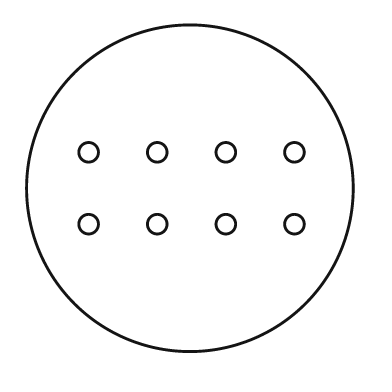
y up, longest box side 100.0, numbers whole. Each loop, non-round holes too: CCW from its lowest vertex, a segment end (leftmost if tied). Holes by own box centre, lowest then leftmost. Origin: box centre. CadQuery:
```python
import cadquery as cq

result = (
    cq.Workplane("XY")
    .moveTo(0.0, 0.0)
    .circle(50.0)
    .moveTo(-31.0, -11.0)
    .circle(3.0)
    .moveTo(-10.0, -11.0)
    .circle(3.0)
    .moveTo(11.0, -11.0)
    .circle(3.0)
    .moveTo(32.0, -11.0)
    .circle(3.0)
    .moveTo(-31.0, 11.0)
    .circle(3.0)
    .moveTo(-10.0, 11.0)
    .circle(3.0)
    .moveTo(11.0, 11.0)
    .circle(3.0)
    .moveTo(32.0, 11.0)
    .circle(3.0)
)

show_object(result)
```